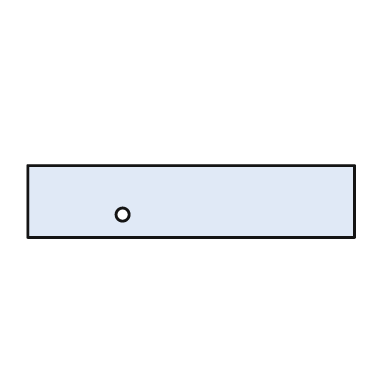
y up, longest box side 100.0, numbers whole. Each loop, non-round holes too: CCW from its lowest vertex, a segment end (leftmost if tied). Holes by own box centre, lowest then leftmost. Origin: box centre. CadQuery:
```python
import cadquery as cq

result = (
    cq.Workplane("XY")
    .moveTo(-50.0, -11.0)
    .lineTo(50.0, -11.0)
    .lineTo(50.0, 11.0)
    .lineTo(-50.0, 11.0)
    .close()
    .moveTo(-21.0, -4.0)
    .circle(2.0)
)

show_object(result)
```